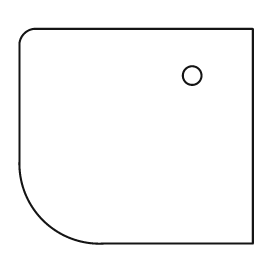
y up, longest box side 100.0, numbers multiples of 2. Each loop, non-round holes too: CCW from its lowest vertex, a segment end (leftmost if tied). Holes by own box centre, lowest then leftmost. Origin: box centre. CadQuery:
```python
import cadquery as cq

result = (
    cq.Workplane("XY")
    .moveTo(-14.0, -46.0)
    .lineTo(50.0, -46.0)
    .lineTo(50.0, 46.0)
    .lineTo(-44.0, 46.0)
    .threePointArc((-48.0, 44.0), (-50.0, 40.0))
    .lineTo(-50.0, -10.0)
    .threePointArc((-40.0, -36.0), (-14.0, -46.0))
    .close()
    .moveTo(24.0, 26.0)
    .circle(4.0)
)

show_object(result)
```